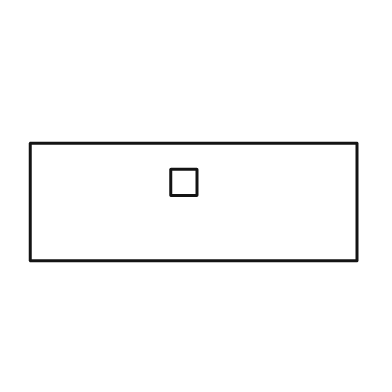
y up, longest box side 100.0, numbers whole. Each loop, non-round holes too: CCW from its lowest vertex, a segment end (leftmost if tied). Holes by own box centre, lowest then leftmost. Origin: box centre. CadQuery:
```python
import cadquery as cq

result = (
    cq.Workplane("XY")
    .moveTo(-50.0, -18.0)
    .lineTo(50.0, -18.0)
    .lineTo(50.0, 18.0)
    .lineTo(-50.0, 18.0)
    .close()
    .moveTo(-7.0, 2.0)
    .lineTo(1.0, 2.0)
    .lineTo(1.0, 10.0)
    .lineTo(-7.0, 10.0)
    .close()
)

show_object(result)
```